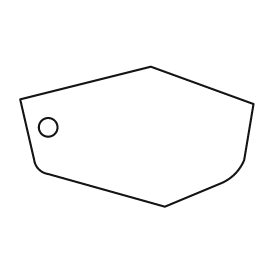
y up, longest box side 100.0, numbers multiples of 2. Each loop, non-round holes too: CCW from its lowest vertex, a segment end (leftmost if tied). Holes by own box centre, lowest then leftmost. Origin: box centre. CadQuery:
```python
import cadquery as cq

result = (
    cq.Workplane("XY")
    .moveTo(12.0, -30.0)
    .lineTo(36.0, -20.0)
    .threePointArc((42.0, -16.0), (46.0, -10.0))
    .lineTo(50.0, 14.0)
    .lineTo(6.0, 30.0)
    .lineTo(-50.0, 16.0)
    .lineTo(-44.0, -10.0)
    .threePointArc((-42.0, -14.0), (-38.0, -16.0))
    .close()
    .moveTo(-38.0, 4.0)
    .circle(4.0)
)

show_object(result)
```